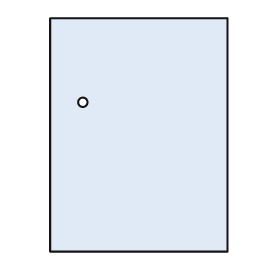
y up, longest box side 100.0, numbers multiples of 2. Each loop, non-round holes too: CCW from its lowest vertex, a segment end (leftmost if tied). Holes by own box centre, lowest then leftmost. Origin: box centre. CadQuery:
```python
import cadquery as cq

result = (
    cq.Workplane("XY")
    .moveTo(-38.0, -50.0)
    .lineTo(38.0, -50.0)
    .lineTo(38.0, 50.0)
    .lineTo(-38.0, 50.0)
    .close()
    .moveTo(-24.0, 14.0)
    .circle(2.0)
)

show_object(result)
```